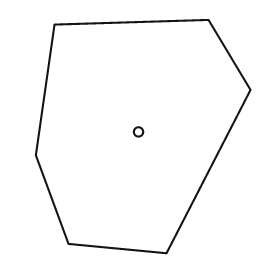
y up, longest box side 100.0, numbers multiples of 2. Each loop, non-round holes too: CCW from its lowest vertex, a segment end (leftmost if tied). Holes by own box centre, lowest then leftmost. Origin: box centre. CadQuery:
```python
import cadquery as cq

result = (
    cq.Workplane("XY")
    .moveTo(10.0, -50.0)
    .lineTo(46.0, 20.0)
    .lineTo(28.0, 50.0)
    .lineTo(-38.0, 48.0)
    .lineTo(-46.0, -8.0)
    .lineTo(-32.0, -46.0)
    .close()
    .moveTo(-2.0, 2.0)
    .circle(2.0)
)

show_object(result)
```